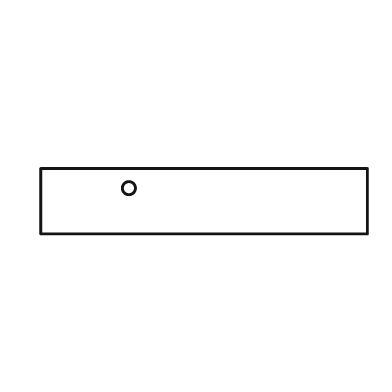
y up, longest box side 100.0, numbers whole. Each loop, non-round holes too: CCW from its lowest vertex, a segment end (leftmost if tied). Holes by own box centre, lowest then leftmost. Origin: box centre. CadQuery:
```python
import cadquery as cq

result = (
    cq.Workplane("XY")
    .moveTo(-50.0, -10.0)
    .lineTo(50.0, -10.0)
    .lineTo(50.0, 10.0)
    .lineTo(-50.0, 10.0)
    .close()
    .moveTo(-23.0, 4.0)
    .circle(2.0)
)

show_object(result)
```